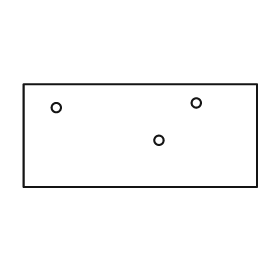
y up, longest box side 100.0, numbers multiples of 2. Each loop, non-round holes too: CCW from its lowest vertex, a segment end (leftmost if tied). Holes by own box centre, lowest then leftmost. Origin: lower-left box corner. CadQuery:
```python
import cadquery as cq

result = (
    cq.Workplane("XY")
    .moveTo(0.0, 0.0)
    .lineTo(100.0, 0.0)
    .lineTo(100.0, 44.0)
    .lineTo(0.0, 44.0)
    .close()
    .moveTo(58.0, 20.0)
    .circle(2.0)
    .moveTo(14.0, 34.0)
    .circle(2.0)
    .moveTo(74.0, 36.0)
    .circle(2.0)
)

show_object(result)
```